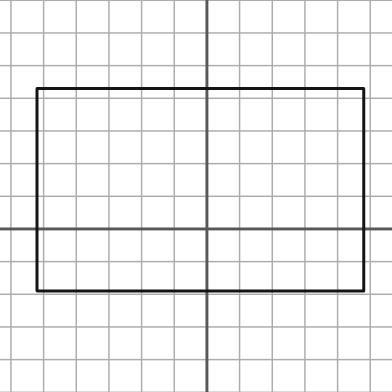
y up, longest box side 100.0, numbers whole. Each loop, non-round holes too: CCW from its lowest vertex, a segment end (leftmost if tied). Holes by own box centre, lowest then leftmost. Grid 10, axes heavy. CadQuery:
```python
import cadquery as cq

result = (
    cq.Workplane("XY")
    .moveTo(-52.0, -19.0)
    .lineTo(48.0, -19.0)
    .lineTo(48.0, 43.0)
    .lineTo(-52.0, 43.0)
    .close()
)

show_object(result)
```